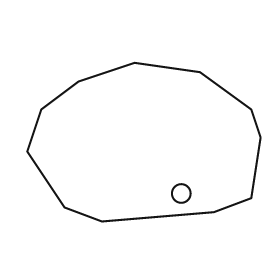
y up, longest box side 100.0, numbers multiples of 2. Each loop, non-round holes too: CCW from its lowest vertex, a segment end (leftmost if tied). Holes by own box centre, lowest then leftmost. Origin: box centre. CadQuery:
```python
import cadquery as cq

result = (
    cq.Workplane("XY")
    .moveTo(-18.0, -34.0)
    .lineTo(30.0, -30.0)
    .lineTo(46.0, -24.0)
    .lineTo(50.0, 2.0)
    .lineTo(46.0, 14.0)
    .lineTo(24.0, 30.0)
    .lineTo(-4.0, 34.0)
    .lineTo(-28.0, 26.0)
    .lineTo(-44.0, 14.0)
    .lineTo(-50.0, -4.0)
    .lineTo(-34.0, -28.0)
    .close()
    .moveTo(16.0, -22.0)
    .circle(4.0)
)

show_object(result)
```